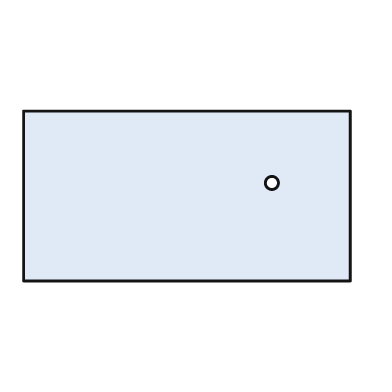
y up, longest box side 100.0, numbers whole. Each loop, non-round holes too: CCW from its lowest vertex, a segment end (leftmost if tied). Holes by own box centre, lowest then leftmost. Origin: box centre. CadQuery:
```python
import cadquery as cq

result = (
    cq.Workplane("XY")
    .moveTo(-50.0, -26.0)
    .lineTo(50.0, -26.0)
    .lineTo(50.0, 26.0)
    .lineTo(-50.0, 26.0)
    .close()
    .moveTo(26.0, 4.0)
    .circle(2.0)
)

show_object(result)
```